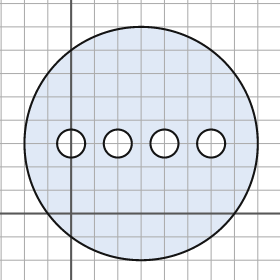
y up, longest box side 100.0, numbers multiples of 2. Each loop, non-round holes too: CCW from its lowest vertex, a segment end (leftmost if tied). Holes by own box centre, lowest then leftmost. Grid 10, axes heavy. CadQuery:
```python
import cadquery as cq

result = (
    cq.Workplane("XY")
    .moveTo(30.0, 30.0)
    .circle(50.0)
    .moveTo(0.0, 30.0)
    .circle(6.0)
    .moveTo(20.0, 30.0)
    .circle(6.0)
    .moveTo(40.0, 30.0)
    .circle(6.0)
    .moveTo(60.0, 30.0)
    .circle(6.0)
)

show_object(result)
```